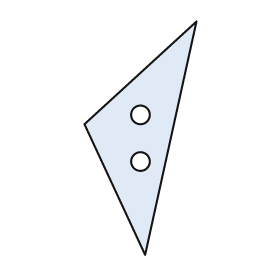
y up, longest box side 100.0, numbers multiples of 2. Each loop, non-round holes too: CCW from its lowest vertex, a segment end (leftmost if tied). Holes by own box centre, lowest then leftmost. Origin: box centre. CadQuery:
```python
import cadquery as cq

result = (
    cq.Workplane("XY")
    .moveTo(2.0, -50.0)
    .lineTo(24.0, 50.0)
    .lineTo(-24.0, 6.0)
    .close()
    .moveTo(0.0, -10.0)
    .circle(4.0)
    .moveTo(0.0, 10.0)
    .circle(4.0)
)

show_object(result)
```